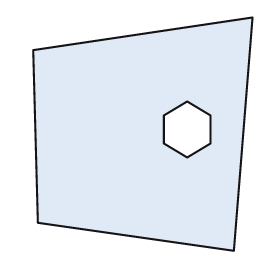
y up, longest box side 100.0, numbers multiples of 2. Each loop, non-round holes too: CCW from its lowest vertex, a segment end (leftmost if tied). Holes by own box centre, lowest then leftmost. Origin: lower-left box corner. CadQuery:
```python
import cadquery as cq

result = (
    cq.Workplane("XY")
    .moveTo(86.0, 0.0)
    .lineTo(94.0, 100.0)
    .lineTo(0.0, 86.0)
    .lineTo(2.0, 12.0)
    .close()
    .moveTo(66.0, 40.0)
    .lineTo(76.0, 46.0)
    .lineTo(76.0, 58.0)
    .lineTo(66.0, 64.0)
    .lineTo(56.0, 58.0)
    .lineTo(56.0, 46.0)
    .close()
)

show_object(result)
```